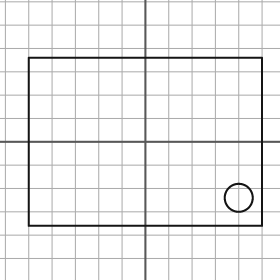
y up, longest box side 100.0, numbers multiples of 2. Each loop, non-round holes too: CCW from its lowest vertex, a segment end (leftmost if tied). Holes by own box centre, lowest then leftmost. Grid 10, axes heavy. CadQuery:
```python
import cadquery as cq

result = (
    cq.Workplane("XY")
    .moveTo(-50.0, -36.0)
    .lineTo(50.0, -36.0)
    .lineTo(50.0, 36.0)
    .lineTo(-50.0, 36.0)
    .close()
    .moveTo(40.0, -24.0)
    .circle(6.0)
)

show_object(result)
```